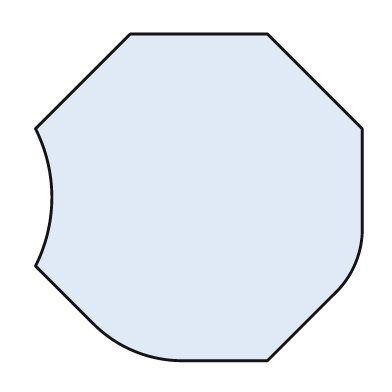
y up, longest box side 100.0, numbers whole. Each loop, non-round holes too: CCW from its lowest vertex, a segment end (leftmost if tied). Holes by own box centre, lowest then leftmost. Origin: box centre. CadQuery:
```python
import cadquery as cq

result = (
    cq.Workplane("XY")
    .moveTo(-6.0, -50.0)
    .lineTo(21.0, -50.0)
    .lineTo(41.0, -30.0)
    .threePointArc((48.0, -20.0), (50.0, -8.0))
    .lineTo(50.0, 21.0)
    .lineTo(21.0, 50.0)
    .lineTo(-21.0, 50.0)
    .lineTo(-50.0, 21.0)
    .threePointArc((-45.0, 0.0), (-50.0, -21.0))
    .lineTo(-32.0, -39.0)
    .threePointArc((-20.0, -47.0), (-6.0, -50.0))
    .close()
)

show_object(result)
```